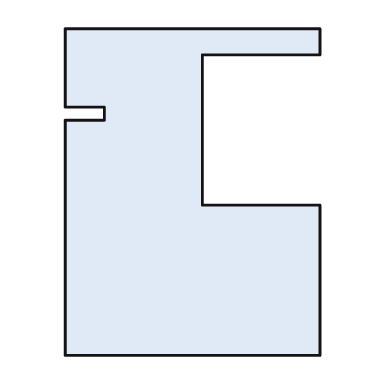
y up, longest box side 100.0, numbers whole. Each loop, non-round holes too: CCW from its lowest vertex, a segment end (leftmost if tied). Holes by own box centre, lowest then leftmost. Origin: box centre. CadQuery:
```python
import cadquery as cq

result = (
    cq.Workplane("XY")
    .moveTo(-39.0, -50.0)
    .lineTo(39.0, -50.0)
    .lineTo(39.0, -4.0)
    .lineTo(3.0, -4.0)
    .lineTo(3.0, 42.0)
    .lineTo(39.0, 42.0)
    .lineTo(39.0, 50.0)
    .lineTo(-39.0, 50.0)
    .lineTo(-39.0, 26.0)
    .lineTo(-27.0, 26.0)
    .lineTo(-27.0, 22.0)
    .lineTo(-39.0, 22.0)
    .close()
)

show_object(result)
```